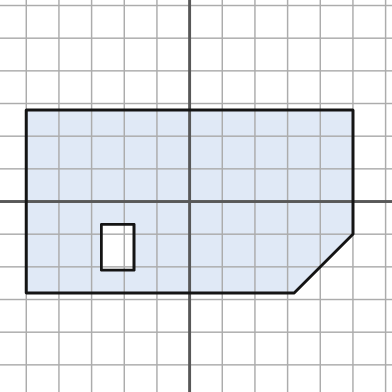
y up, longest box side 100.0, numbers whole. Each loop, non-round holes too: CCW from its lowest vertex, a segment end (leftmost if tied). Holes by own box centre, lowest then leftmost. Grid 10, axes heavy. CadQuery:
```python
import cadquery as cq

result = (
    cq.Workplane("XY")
    .moveTo(-50.0, -28.0)
    .lineTo(32.0, -28.0)
    .lineTo(50.0, -10.0)
    .lineTo(50.0, 28.0)
    .lineTo(-50.0, 28.0)
    .close()
    .moveTo(-27.0, -21.0)
    .lineTo(-17.0, -21.0)
    .lineTo(-17.0, -7.0)
    .lineTo(-27.0, -7.0)
    .close()
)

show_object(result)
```